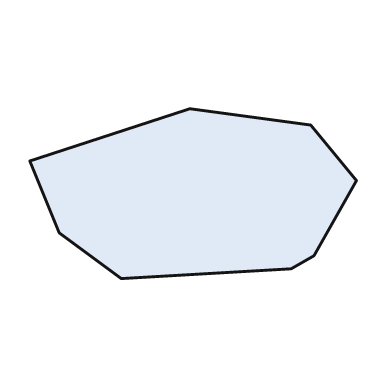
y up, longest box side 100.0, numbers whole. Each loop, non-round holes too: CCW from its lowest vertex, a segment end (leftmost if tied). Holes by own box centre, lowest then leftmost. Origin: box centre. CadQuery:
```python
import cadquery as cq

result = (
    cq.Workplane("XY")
    .moveTo(-22.0, -26.0)
    .lineTo(30.0, -23.0)
    .lineTo(37.0, -19.0)
    .lineTo(50.0, 4.0)
    .lineTo(36.0, 21.0)
    .lineTo(-1.0, 26.0)
    .lineTo(-50.0, 10.0)
    .lineTo(-41.0, -12.0)
    .close()
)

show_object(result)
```